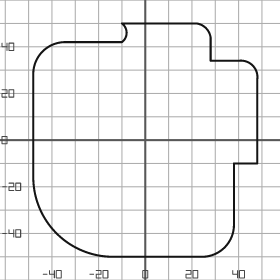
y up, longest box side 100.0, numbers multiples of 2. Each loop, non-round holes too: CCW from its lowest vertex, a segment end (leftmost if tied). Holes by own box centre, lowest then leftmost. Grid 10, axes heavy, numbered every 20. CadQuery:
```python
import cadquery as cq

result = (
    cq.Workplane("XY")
    .moveTo(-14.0, -50.0)
    .lineTo(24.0, -50.0)
    .threePointArc((34.0, -46.0), (38.0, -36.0))
    .lineTo(38.0, -10.0)
    .lineTo(48.0, -10.0)
    .lineTo(48.0, 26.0)
    .threePointArc((46.0, 32.0), (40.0, 34.0))
    .lineTo(28.0, 34.0)
    .lineTo(28.0, 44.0)
    .threePointArc((26.0, 48.0), (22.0, 50.0))
    .lineTo(-10.0, 50.0)
    .threePointArc((-8.0, 46.0), (-10.0, 42.0))
    .lineTo(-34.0, 42.0)
    .threePointArc((-44.0, 38.0), (-48.0, 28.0))
    .lineTo(-48.0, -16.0)
    .threePointArc((-38.0, -40.0), (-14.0, -50.0))
    .close()
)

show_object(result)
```